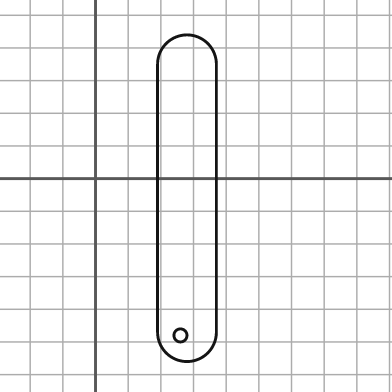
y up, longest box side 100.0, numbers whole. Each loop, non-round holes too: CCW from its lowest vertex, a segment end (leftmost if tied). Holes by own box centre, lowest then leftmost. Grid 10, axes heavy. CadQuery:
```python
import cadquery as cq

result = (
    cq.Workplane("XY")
    .moveTo(19.0, -47.0)
    .threePointArc((28.0, -56.0), (37.0, -47.0))
    .lineTo(37.0, 35.0)
    .threePointArc((28.0, 44.0), (19.0, 35.0))
    .close()
    .moveTo(26.0, -48.0)
    .circle(2.0)
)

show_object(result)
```